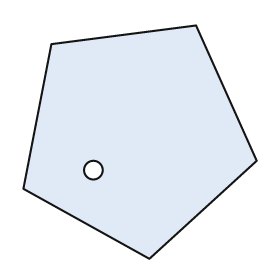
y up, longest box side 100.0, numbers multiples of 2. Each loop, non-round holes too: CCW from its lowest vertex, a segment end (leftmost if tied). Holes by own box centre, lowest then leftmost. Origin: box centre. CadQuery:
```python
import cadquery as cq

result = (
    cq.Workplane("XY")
    .moveTo(4.0, -50.0)
    .lineTo(50.0, -8.0)
    .lineTo(24.0, 50.0)
    .lineTo(-38.0, 42.0)
    .lineTo(-50.0, -20.0)
    .close()
    .moveTo(-20.0, -12.0)
    .circle(4.0)
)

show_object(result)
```